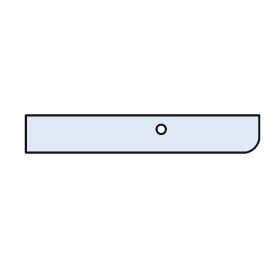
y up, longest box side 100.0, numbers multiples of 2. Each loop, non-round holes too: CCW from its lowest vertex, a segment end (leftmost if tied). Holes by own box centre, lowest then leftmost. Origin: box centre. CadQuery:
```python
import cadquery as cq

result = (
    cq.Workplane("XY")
    .moveTo(-50.0, -8.0)
    .lineTo(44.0, -8.0)
    .threePointArc((48.0, -6.0), (50.0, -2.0))
    .lineTo(50.0, 8.0)
    .lineTo(-50.0, 8.0)
    .close()
    .moveTo(8.0, 2.0)
    .circle(2.0)
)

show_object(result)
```